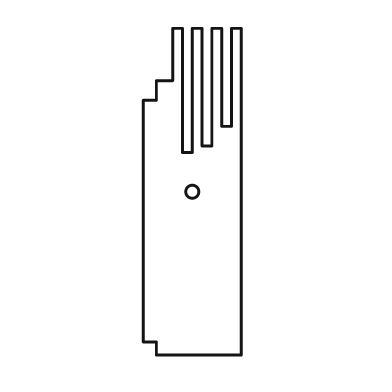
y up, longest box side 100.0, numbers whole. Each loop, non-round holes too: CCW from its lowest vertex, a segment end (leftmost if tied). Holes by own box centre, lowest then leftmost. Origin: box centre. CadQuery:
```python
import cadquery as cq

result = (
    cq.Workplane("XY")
    .moveTo(-11.0, -50.0)
    .lineTo(15.0, -50.0)
    .lineTo(15.0, 50.0)
    .lineTo(12.0, 50.0)
    .lineTo(12.0, 20.0)
    .lineTo(9.0, 20.0)
    .lineTo(9.0, 50.0)
    .lineTo(6.0, 50.0)
    .lineTo(6.0, 14.0)
    .lineTo(3.0, 14.0)
    .lineTo(3.0, 50.0)
    .lineTo(0.0, 50.0)
    .lineTo(0.0, 12.0)
    .lineTo(-3.0, 12.0)
    .lineTo(-3.0, 50.0)
    .lineTo(-6.0, 50.0)
    .lineTo(-6.0, 34.0)
    .lineTo(-11.0, 34.0)
    .lineTo(-11.0, 28.0)
    .lineTo(-15.0, 28.0)
    .lineTo(-15.0, -46.0)
    .lineTo(-11.0, -46.0)
    .close()
    .moveTo(0.0, 0.0)
    .circle(2.0)
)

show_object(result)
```